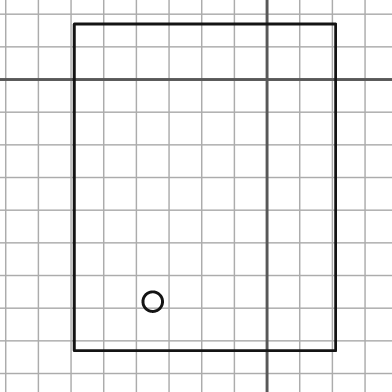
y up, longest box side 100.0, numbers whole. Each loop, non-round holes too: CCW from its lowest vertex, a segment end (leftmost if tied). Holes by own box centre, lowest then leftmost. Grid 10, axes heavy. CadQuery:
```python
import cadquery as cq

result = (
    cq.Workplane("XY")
    .moveTo(-59.0, -83.0)
    .lineTo(21.0, -83.0)
    .lineTo(21.0, 17.0)
    .lineTo(-59.0, 17.0)
    .close()
    .moveTo(-35.0, -68.0)
    .circle(3.0)
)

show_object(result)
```